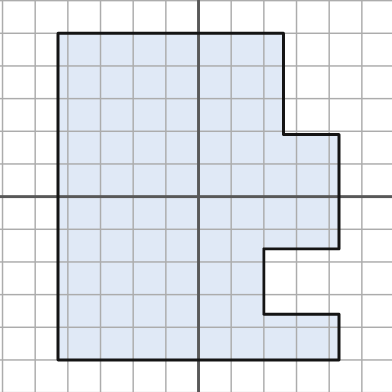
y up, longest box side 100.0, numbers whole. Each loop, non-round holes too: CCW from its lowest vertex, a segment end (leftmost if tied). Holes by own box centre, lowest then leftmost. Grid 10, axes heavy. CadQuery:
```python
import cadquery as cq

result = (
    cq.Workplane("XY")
    .moveTo(-43.0, -50.0)
    .lineTo(43.0, -50.0)
    .lineTo(43.0, -36.0)
    .lineTo(20.0, -36.0)
    .lineTo(20.0, -16.0)
    .lineTo(43.0, -16.0)
    .lineTo(43.0, 19.0)
    .lineTo(26.0, 19.0)
    .lineTo(26.0, 50.0)
    .lineTo(-43.0, 50.0)
    .close()
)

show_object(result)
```